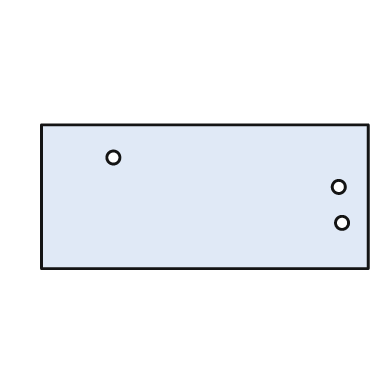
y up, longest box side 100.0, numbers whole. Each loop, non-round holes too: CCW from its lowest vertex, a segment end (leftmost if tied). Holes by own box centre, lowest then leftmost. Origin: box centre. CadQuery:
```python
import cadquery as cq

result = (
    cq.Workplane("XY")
    .moveTo(-50.0, -22.0)
    .lineTo(50.0, -22.0)
    .lineTo(50.0, 22.0)
    .lineTo(-50.0, 22.0)
    .close()
    .moveTo(42.0, -8.0)
    .circle(2.0)
    .moveTo(41.0, 3.0)
    .circle(2.0)
    .moveTo(-28.0, 12.0)
    .circle(2.0)
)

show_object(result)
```